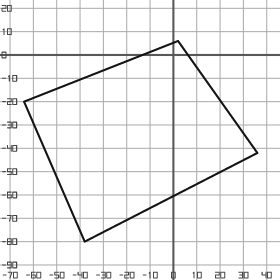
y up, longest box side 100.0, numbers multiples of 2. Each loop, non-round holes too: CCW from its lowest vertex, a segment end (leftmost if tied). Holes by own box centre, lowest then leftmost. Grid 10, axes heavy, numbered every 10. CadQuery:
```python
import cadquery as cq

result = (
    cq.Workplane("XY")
    .moveTo(-38.0, -80.0)
    .lineTo(36.0, -42.0)
    .lineTo(2.0, 6.0)
    .lineTo(-64.0, -20.0)
    .close()
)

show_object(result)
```